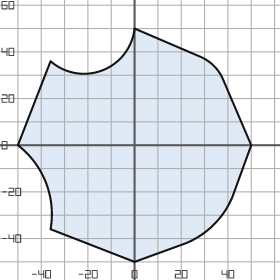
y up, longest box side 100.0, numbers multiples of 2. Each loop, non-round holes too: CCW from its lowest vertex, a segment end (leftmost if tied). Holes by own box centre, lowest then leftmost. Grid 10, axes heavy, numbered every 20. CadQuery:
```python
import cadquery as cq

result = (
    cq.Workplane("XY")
    .moveTo(0.0, -50.0)
    .lineTo(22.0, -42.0)
    .threePointArc((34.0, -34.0), (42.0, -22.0))
    .lineTo(50.0, 0.0)
    .lineTo(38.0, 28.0)
    .threePointArc((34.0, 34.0), (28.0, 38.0))
    .lineTo(0.0, 50.0)
    .threePointArc((-14.0, 32.0), (-36.0, 36.0))
    .lineTo(-50.0, 0.0)
    .threePointArc((-38.0, -16.0), (-36.0, -36.0))
    .close()
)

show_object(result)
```